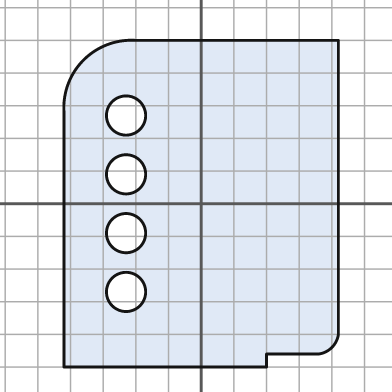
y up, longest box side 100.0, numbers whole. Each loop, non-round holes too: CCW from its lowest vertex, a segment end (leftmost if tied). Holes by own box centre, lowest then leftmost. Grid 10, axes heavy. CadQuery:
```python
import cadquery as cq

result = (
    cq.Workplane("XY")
    .moveTo(-42.0, -50.0)
    .lineTo(20.0, -50.0)
    .lineTo(20.0, -46.0)
    .lineTo(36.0, -46.0)
    .threePointArc((40.0, -44.0), (42.0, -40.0))
    .lineTo(42.0, 50.0)
    .lineTo(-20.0, 50.0)
    .threePointArc((-36.0, 44.0), (-42.0, 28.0))
    .close()
    .moveTo(-23.0, -27.0)
    .circle(6.0)
    .moveTo(-23.0, -9.0)
    .circle(6.0)
    .moveTo(-23.0, 9.0)
    .circle(6.0)
    .moveTo(-23.0, 27.0)
    .circle(6.0)
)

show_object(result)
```